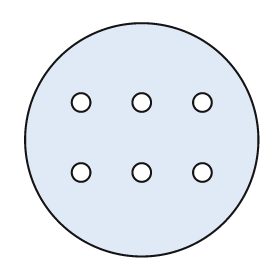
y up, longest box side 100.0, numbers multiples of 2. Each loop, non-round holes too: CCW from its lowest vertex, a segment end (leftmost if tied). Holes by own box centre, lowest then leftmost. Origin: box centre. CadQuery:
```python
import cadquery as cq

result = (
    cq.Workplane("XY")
    .moveTo(0.0, 0.0)
    .circle(50.0)
    .moveTo(-26.0, -14.0)
    .circle(4.0)
    .moveTo(0.0, -14.0)
    .circle(4.0)
    .moveTo(26.0, -14.0)
    .circle(4.0)
    .moveTo(-26.0, 16.0)
    .circle(4.0)
    .moveTo(0.0, 16.0)
    .circle(4.0)
    .moveTo(26.0, 16.0)
    .circle(4.0)
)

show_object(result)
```